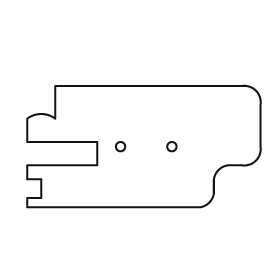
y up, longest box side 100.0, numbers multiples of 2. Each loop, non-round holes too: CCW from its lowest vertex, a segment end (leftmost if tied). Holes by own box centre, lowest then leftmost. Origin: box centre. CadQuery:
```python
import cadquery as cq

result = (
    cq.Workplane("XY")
    .moveTo(-50.0, -26.0)
    .lineTo(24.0, -26.0)
    .threePointArc((28.0, -24.0), (30.0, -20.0))
    .lineTo(30.0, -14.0)
    .threePointArc((32.0, -10.0), (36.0, -8.0))
    .lineTo(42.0, -8.0)
    .threePointArc((48.0, -6.0), (50.0, 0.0))
    .lineTo(50.0, 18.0)
    .threePointArc((48.0, 24.0), (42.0, 26.0))
    .lineTo(-38.0, 26.0)
    .lineTo(-38.0, 12.0)
    .threePointArc((-44.0, 14.0), (-50.0, 12.0))
    .lineTo(-50.0, 2.0)
    .lineTo(-20.0, 2.0)
    .lineTo(-20.0, -8.0)
    .lineTo(-50.0, -8.0)
    .lineTo(-50.0, -14.0)
    .lineTo(-44.0, -14.0)
    .lineTo(-44.0, -22.0)
    .lineTo(-50.0, -22.0)
    .close()
    .moveTo(-10.0, 0.0)
    .circle(2.0)
    .moveTo(12.0, 0.0)
    .circle(2.0)
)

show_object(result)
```